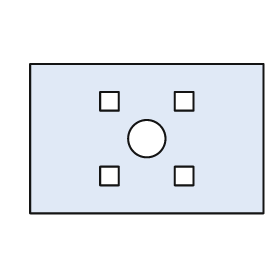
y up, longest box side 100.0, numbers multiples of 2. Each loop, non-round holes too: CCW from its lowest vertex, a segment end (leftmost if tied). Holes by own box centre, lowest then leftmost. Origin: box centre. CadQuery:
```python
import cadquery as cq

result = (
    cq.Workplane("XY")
    .moveTo(-50.0, -32.0)
    .lineTo(50.0, -32.0)
    .lineTo(50.0, 32.0)
    .lineTo(-50.0, 32.0)
    .close()
    .moveTo(-20.0, -20.0)
    .lineTo(-12.0, -20.0)
    .lineTo(-12.0, -12.0)
    .lineTo(-20.0, -12.0)
    .close()
    .moveTo(12.0, -20.0)
    .lineTo(20.0, -20.0)
    .lineTo(20.0, -12.0)
    .lineTo(12.0, -12.0)
    .close()
    .moveTo(0.0, 0.0)
    .circle(8.0)
    .moveTo(-20.0, 12.0)
    .lineTo(-12.0, 12.0)
    .lineTo(-12.0, 20.0)
    .lineTo(-20.0, 20.0)
    .close()
    .moveTo(12.0, 12.0)
    .lineTo(20.0, 12.0)
    .lineTo(20.0, 20.0)
    .lineTo(12.0, 20.0)
    .close()
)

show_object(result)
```